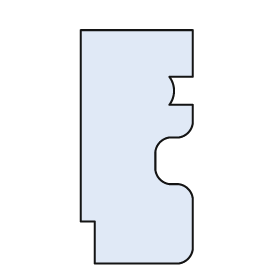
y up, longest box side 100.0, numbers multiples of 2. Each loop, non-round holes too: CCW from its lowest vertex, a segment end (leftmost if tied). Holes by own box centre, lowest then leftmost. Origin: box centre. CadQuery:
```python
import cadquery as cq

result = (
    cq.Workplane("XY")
    .moveTo(-18.0, -50.0)
    .lineTo(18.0, -50.0)
    .threePointArc((22.0, -48.0), (24.0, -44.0))
    .lineTo(24.0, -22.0)
    .threePointArc((22.0, -18.0), (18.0, -16.0))
    .lineTo(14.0, -16.0)
    .threePointArc((10.0, -14.0), (8.0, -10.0))
    .lineTo(8.0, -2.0)
    .threePointArc((10.0, 2.0), (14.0, 4.0))
    .lineTo(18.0, 4.0)
    .threePointArc((22.0, 6.0), (24.0, 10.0))
    .lineTo(24.0, 18.0)
    .lineTo(14.0, 18.0)
    .threePointArc((16.0, 24.0), (14.0, 30.0))
    .lineTo(24.0, 30.0)
    .lineTo(24.0, 50.0)
    .lineTo(-24.0, 50.0)
    .lineTo(-24.0, -32.0)
    .lineTo(-18.0, -32.0)
    .close()
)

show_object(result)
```